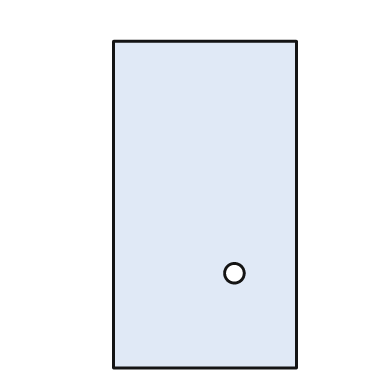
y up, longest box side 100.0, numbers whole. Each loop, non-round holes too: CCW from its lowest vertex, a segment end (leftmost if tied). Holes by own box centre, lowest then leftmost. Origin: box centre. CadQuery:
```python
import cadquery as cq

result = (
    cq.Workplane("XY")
    .moveTo(-28.0, -50.0)
    .lineTo(28.0, -50.0)
    .lineTo(28.0, 50.0)
    .lineTo(-28.0, 50.0)
    .close()
    .moveTo(9.0, -21.0)
    .circle(3.0)
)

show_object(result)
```